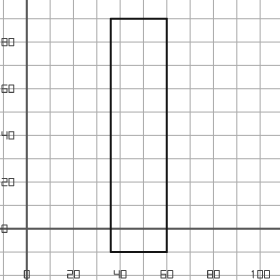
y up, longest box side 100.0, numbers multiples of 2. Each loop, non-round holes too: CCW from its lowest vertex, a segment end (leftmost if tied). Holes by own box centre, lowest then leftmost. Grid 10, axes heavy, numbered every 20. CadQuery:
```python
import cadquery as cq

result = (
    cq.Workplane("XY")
    .moveTo(36.0, -10.0)
    .lineTo(60.0, -10.0)
    .lineTo(60.0, 90.0)
    .lineTo(36.0, 90.0)
    .close()
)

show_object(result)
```